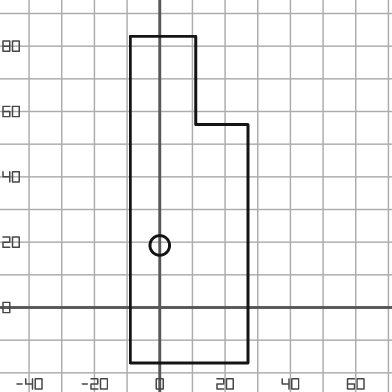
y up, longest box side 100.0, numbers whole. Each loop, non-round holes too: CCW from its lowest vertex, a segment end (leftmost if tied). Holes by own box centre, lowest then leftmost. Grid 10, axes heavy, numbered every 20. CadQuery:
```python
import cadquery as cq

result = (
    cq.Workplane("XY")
    .moveTo(-9.0, -17.0)
    .lineTo(27.0, -17.0)
    .lineTo(27.0, 56.0)
    .lineTo(11.0, 56.0)
    .lineTo(11.0, 83.0)
    .lineTo(-9.0, 83.0)
    .close()
    .moveTo(0.0, 19.0)
    .circle(3.0)
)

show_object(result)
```